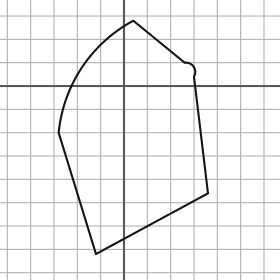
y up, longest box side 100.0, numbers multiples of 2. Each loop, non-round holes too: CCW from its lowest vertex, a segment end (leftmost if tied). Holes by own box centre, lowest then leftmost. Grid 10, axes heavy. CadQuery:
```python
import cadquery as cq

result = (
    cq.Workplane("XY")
    .moveTo(-12.0, -72.0)
    .lineTo(36.0, -46.0)
    .lineTo(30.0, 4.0)
    .threePointArc((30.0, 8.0), (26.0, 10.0))
    .lineTo(4.0, 28.0)
    .threePointArc((-18.0, 8.0), (-28.0, -20.0))
    .close()
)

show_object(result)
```